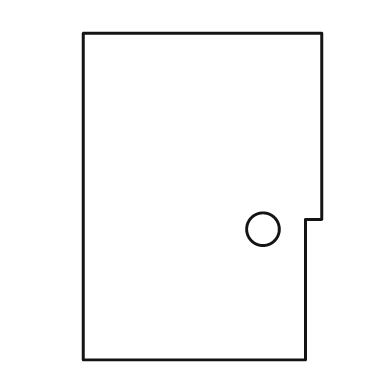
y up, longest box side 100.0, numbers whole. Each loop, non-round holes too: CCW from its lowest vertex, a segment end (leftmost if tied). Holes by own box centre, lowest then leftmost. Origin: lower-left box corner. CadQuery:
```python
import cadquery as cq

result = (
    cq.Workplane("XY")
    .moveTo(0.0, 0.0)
    .lineTo(68.0, 0.0)
    .lineTo(68.0, 43.0)
    .lineTo(73.0, 43.0)
    .lineTo(73.0, 100.0)
    .lineTo(0.0, 100.0)
    .close()
    .moveTo(55.0, 40.0)
    .circle(5.0)
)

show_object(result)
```